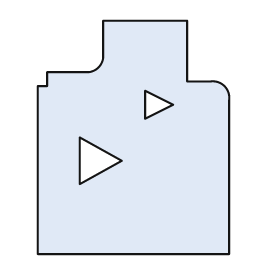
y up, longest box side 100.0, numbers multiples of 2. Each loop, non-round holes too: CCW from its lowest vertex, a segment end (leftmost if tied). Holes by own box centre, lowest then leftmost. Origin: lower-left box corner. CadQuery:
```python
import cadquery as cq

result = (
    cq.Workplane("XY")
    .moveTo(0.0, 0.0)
    .lineTo(82.0, 0.0)
    .lineTo(82.0, 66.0)
    .threePointArc((80.0, 72.0), (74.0, 74.0))
    .lineTo(64.0, 74.0)
    .lineTo(64.0, 100.0)
    .lineTo(28.0, 100.0)
    .lineTo(28.0, 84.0)
    .threePointArc((26.0, 80.0), (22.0, 78.0))
    .lineTo(4.0, 78.0)
    .lineTo(4.0, 72.0)
    .lineTo(0.0, 72.0)
    .close()
    .moveTo(18.0, 30.0)
    .lineTo(36.0, 40.0)
    .lineTo(18.0, 50.0)
    .close()
    .moveTo(46.0, 58.0)
    .lineTo(58.0, 64.0)
    .lineTo(46.0, 70.0)
    .close()
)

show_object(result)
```